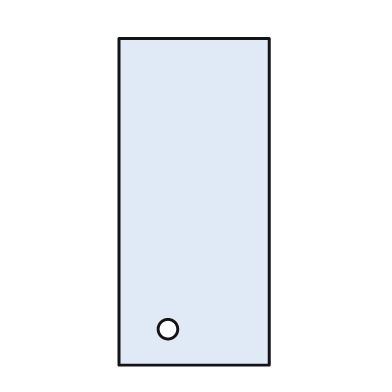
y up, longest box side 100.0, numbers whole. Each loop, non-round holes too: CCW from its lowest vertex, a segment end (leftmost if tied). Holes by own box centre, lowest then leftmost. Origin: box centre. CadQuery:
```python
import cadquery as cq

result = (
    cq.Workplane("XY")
    .moveTo(-23.0, -50.0)
    .lineTo(23.0, -50.0)
    .lineTo(23.0, 50.0)
    .lineTo(-23.0, 50.0)
    .close()
    .moveTo(-8.0, -39.0)
    .circle(3.0)
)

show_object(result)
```